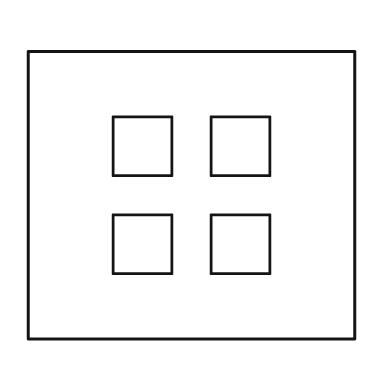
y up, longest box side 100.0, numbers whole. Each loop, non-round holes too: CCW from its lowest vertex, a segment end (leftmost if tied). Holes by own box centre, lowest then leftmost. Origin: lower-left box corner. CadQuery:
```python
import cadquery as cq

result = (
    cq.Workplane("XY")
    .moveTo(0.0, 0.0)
    .lineTo(100.0, 0.0)
    .lineTo(100.0, 88.0)
    .lineTo(0.0, 88.0)
    .close()
    .moveTo(26.0, 20.0)
    .lineTo(44.0, 20.0)
    .lineTo(44.0, 38.0)
    .lineTo(26.0, 38.0)
    .close()
    .moveTo(56.0, 20.0)
    .lineTo(74.0, 20.0)
    .lineTo(74.0, 38.0)
    .lineTo(56.0, 38.0)
    .close()
    .moveTo(26.0, 50.0)
    .lineTo(44.0, 50.0)
    .lineTo(44.0, 68.0)
    .lineTo(26.0, 68.0)
    .close()
    .moveTo(56.0, 50.0)
    .lineTo(74.0, 50.0)
    .lineTo(74.0, 68.0)
    .lineTo(56.0, 68.0)
    .close()
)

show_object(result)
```